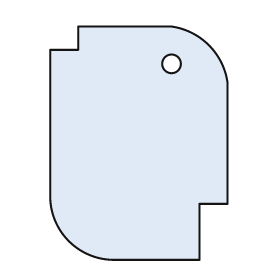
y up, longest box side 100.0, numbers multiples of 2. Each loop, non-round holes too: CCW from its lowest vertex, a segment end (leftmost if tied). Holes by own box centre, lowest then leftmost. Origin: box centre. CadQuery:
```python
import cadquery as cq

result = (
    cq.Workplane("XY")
    .moveTo(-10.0, -50.0)
    .lineTo(26.0, -50.0)
    .lineTo(26.0, -26.0)
    .lineTo(38.0, -26.0)
    .lineTo(38.0, 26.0)
    .threePointArc((30.0, 42.0), (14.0, 50.0))
    .lineTo(-26.0, 50.0)
    .lineTo(-26.0, 40.0)
    .lineTo(-38.0, 40.0)
    .lineTo(-38.0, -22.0)
    .threePointArc((-30.0, -42.0), (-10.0, -50.0))
    .close()
    .moveTo(14.0, 34.0)
    .circle(4.0)
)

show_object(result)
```